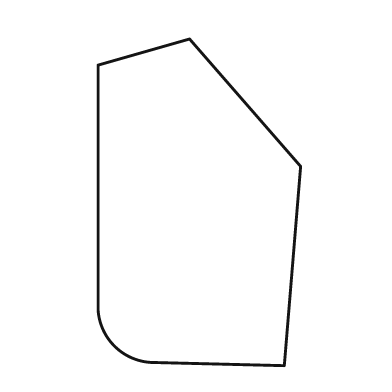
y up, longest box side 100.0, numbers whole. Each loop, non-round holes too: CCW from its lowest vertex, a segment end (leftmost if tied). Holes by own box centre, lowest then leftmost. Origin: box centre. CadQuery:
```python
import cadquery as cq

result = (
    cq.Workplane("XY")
    .moveTo(26.0, -50.0)
    .lineTo(31.0, 11.0)
    .lineTo(-3.0, 50.0)
    .lineTo(-31.0, 42.0)
    .lineTo(-31.0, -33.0)
    .threePointArc((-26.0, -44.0), (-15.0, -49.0))
    .close()
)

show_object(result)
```